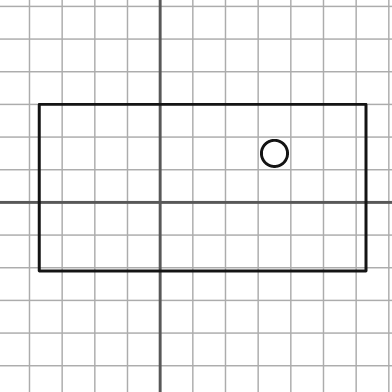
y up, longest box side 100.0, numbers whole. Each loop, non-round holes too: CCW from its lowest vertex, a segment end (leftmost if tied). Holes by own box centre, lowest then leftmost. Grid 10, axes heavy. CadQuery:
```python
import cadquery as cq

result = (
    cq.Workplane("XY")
    .moveTo(-37.0, -21.0)
    .lineTo(63.0, -21.0)
    .lineTo(63.0, 30.0)
    .lineTo(-37.0, 30.0)
    .close()
    .moveTo(35.0, 15.0)
    .circle(4.0)
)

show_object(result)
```